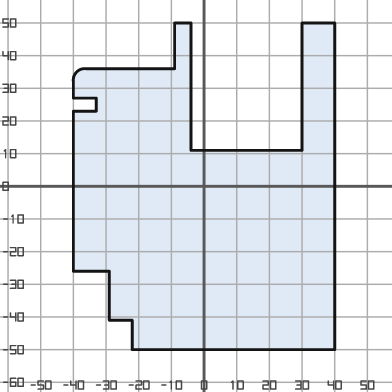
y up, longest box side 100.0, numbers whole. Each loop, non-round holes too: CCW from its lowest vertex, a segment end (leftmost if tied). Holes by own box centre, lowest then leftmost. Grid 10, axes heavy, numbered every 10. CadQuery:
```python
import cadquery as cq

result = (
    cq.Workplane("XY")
    .moveTo(-22.0, -50.0)
    .lineTo(40.0, -50.0)
    .lineTo(40.0, 50.0)
    .lineTo(30.0, 50.0)
    .lineTo(30.0, 11.0)
    .lineTo(-4.0, 11.0)
    .lineTo(-4.0, 50.0)
    .lineTo(-9.0, 50.0)
    .lineTo(-9.0, 36.0)
    .lineTo(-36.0, 36.0)
    .threePointArc((-39.0, 35.0), (-40.0, 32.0))
    .lineTo(-40.0, 27.0)
    .lineTo(-33.0, 27.0)
    .lineTo(-33.0, 23.0)
    .lineTo(-40.0, 23.0)
    .lineTo(-40.0, -26.0)
    .lineTo(-29.0, -26.0)
    .lineTo(-29.0, -41.0)
    .lineTo(-22.0, -41.0)
    .close()
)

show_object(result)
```